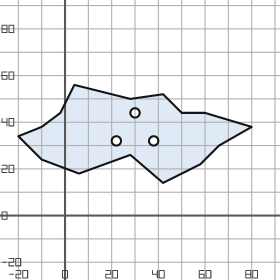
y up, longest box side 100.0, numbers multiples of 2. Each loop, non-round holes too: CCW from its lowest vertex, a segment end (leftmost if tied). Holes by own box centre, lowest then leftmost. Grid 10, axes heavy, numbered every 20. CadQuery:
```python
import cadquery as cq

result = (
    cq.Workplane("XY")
    .moveTo(42.0, 14.0)
    .lineTo(58.0, 22.0)
    .lineTo(66.0, 30.0)
    .lineTo(80.0, 38.0)
    .lineTo(60.0, 44.0)
    .lineTo(50.0, 44.0)
    .lineTo(42.0, 52.0)
    .lineTo(28.0, 50.0)
    .lineTo(4.0, 56.0)
    .lineTo(-2.0, 44.0)
    .lineTo(-10.0, 38.0)
    .lineTo(-20.0, 34.0)
    .lineTo(-10.0, 24.0)
    .lineTo(6.0, 18.0)
    .lineTo(28.0, 26.0)
    .close()
    .moveTo(22.0, 32.0)
    .circle(2.0)
    .moveTo(38.0, 32.0)
    .circle(2.0)
    .moveTo(30.0, 44.0)
    .circle(2.0)
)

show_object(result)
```